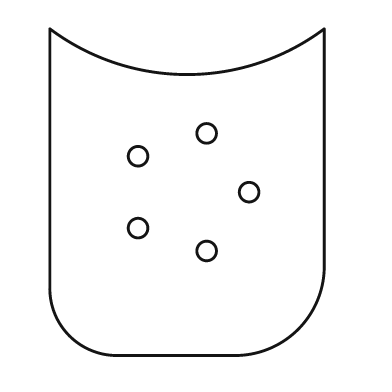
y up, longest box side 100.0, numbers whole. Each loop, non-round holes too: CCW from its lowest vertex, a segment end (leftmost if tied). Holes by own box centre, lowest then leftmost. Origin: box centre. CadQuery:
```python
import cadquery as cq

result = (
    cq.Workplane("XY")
    .moveTo(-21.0, -50.0)
    .lineTo(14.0, -50.0)
    .threePointArc((34.0, -42.0), (42.0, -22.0))
    .lineTo(42.0, 50.0)
    .threePointArc((0.0, 36.0), (-42.0, 50.0))
    .lineTo(-42.0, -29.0)
    .threePointArc((-36.0, -44.0), (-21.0, -50.0))
    .close()
    .moveTo(6.0, -18.0)
    .circle(3.0)
    .moveTo(-15.0, -11.0)
    .circle(3.0)
    .moveTo(19.0, 0.0)
    .circle(3.0)
    .moveTo(-15.0, 11.0)
    .circle(3.0)
    .moveTo(6.0, 18.0)
    .circle(3.0)
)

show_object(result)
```